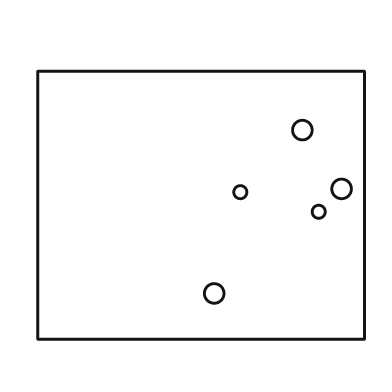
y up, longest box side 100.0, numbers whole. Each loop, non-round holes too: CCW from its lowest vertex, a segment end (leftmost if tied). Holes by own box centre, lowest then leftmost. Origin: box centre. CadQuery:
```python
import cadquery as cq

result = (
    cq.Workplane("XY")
    .moveTo(-50.0, -41.0)
    .lineTo(50.0, -41.0)
    .lineTo(50.0, 41.0)
    .lineTo(-50.0, 41.0)
    .close()
    .moveTo(4.0, -27.0)
    .circle(3.0)
    .moveTo(36.0, -2.0)
    .circle(2.0)
    .moveTo(12.0, 4.0)
    .circle(2.0)
    .moveTo(43.0, 5.0)
    .circle(3.0)
    .moveTo(31.0, 23.0)
    .circle(3.0)
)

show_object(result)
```